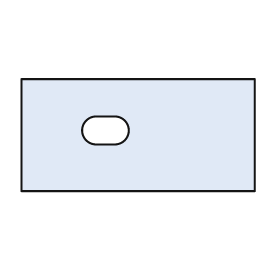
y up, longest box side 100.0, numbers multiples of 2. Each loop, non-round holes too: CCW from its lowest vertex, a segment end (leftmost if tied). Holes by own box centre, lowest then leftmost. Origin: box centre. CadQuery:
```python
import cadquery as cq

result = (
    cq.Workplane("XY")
    .moveTo(-50.0, -24.0)
    .lineTo(50.0, -24.0)
    .lineTo(50.0, 24.0)
    .lineTo(-50.0, 24.0)
    .close()
    .moveTo(-18.0, -4.0)
    .lineTo(-10.0, -4.0)
    .threePointArc((-4.0, 2.0), (-10.0, 8.0))
    .lineTo(-18.0, 8.0)
    .threePointArc((-24.0, 2.0), (-18.0, -4.0))
    .close()
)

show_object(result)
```